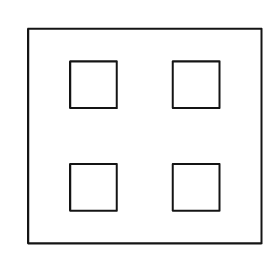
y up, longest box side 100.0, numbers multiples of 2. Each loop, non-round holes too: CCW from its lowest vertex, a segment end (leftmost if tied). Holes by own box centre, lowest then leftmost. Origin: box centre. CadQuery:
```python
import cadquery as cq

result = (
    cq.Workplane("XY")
    .moveTo(-50.0, -46.0)
    .lineTo(50.0, -46.0)
    .lineTo(50.0, 46.0)
    .lineTo(-50.0, 46.0)
    .close()
    .moveTo(-32.0, -32.0)
    .lineTo(-12.0, -32.0)
    .lineTo(-12.0, -12.0)
    .lineTo(-32.0, -12.0)
    .close()
    .moveTo(12.0, -32.0)
    .lineTo(32.0, -32.0)
    .lineTo(32.0, -12.0)
    .lineTo(12.0, -12.0)
    .close()
    .moveTo(-32.0, 12.0)
    .lineTo(-12.0, 12.0)
    .lineTo(-12.0, 32.0)
    .lineTo(-32.0, 32.0)
    .close()
    .moveTo(12.0, 12.0)
    .lineTo(32.0, 12.0)
    .lineTo(32.0, 32.0)
    .lineTo(12.0, 32.0)
    .close()
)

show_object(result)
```